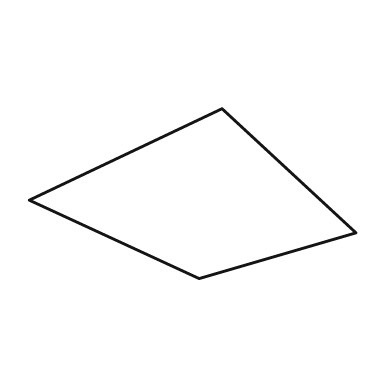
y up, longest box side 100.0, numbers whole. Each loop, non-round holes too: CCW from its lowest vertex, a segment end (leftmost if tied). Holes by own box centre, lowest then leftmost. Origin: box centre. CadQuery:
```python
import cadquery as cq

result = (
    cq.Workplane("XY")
    .moveTo(2.0, -26.0)
    .lineTo(50.0, -12.0)
    .lineTo(9.0, 26.0)
    .lineTo(-50.0, -2.0)
    .close()
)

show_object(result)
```